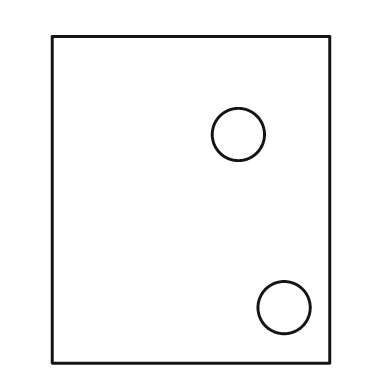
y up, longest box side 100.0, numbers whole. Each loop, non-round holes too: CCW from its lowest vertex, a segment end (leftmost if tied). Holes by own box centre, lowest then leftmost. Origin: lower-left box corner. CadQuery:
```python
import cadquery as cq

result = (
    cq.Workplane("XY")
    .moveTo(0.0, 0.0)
    .lineTo(85.0, 0.0)
    .lineTo(85.0, 100.0)
    .lineTo(0.0, 100.0)
    .close()
    .moveTo(71.0, 17.0)
    .circle(8.0)
    .moveTo(57.0, 70.0)
    .circle(8.0)
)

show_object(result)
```